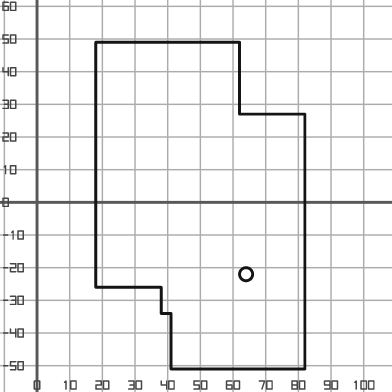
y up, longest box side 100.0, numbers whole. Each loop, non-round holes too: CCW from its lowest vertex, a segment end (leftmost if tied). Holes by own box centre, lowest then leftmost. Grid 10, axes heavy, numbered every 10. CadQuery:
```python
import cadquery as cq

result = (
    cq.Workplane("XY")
    .moveTo(41.0, -51.0)
    .lineTo(82.0, -51.0)
    .lineTo(82.0, 27.0)
    .lineTo(62.0, 27.0)
    .lineTo(62.0, 49.0)
    .lineTo(18.0, 49.0)
    .lineTo(18.0, -26.0)
    .lineTo(38.0, -26.0)
    .lineTo(38.0, -34.0)
    .lineTo(41.0, -34.0)
    .close()
    .moveTo(64.0, -22.0)
    .circle(2.0)
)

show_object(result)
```